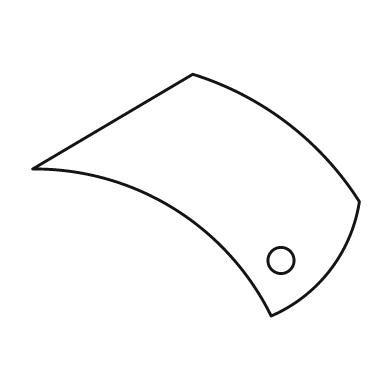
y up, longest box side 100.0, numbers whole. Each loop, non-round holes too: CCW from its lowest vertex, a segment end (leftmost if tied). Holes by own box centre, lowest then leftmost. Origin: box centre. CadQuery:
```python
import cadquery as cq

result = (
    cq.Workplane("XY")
    .moveTo(23.0, -37.0)
    .threePointArc((41.0, -23.0), (50.0, -2.0))
    .threePointArc((28.0, 22.0), (-1.0, 37.0))
    .lineTo(-50.0, 8.0)
    .threePointArc((-7.0, -4.0), (23.0, -37.0))
    .close()
    .moveTo(26.0, -20.0)
    .circle(4.0)
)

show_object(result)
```